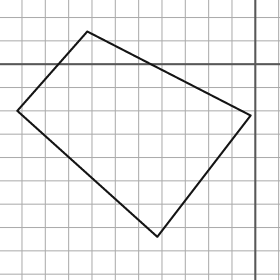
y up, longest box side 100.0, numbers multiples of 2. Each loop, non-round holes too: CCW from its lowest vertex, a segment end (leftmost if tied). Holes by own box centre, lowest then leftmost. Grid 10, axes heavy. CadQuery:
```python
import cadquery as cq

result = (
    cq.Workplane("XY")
    .moveTo(-42.0, -74.0)
    .lineTo(-2.0, -22.0)
    .lineTo(-72.0, 14.0)
    .lineTo(-102.0, -20.0)
    .close()
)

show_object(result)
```